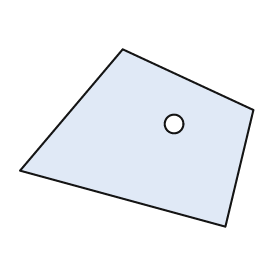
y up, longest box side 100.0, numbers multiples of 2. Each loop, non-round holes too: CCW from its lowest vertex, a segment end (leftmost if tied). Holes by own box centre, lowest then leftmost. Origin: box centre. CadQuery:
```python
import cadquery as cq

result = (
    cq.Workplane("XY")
    .moveTo(38.0, -38.0)
    .lineTo(50.0, 12.0)
    .lineTo(-6.0, 38.0)
    .lineTo(-50.0, -14.0)
    .close()
    .moveTo(16.0, 6.0)
    .circle(4.0)
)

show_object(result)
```